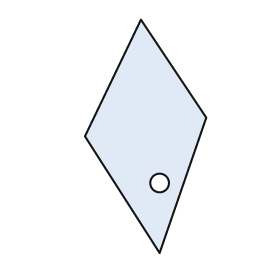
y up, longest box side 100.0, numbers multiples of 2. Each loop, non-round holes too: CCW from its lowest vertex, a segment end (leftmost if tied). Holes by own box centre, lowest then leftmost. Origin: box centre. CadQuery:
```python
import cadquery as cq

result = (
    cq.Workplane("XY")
    .moveTo(6.0, -50.0)
    .lineTo(26.0, 8.0)
    .lineTo(-2.0, 50.0)
    .lineTo(-26.0, 0.0)
    .close()
    .moveTo(6.0, -20.0)
    .circle(4.0)
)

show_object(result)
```